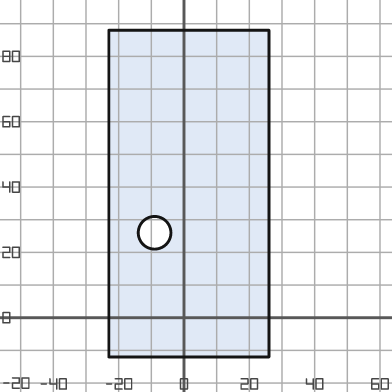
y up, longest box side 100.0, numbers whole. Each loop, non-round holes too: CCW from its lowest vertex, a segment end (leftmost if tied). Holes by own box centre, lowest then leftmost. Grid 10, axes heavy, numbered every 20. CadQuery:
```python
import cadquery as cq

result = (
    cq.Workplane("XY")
    .moveTo(-23.0, -12.0)
    .lineTo(26.0, -12.0)
    .lineTo(26.0, 88.0)
    .lineTo(-23.0, 88.0)
    .close()
    .moveTo(-9.0, 26.0)
    .circle(5.0)
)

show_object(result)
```